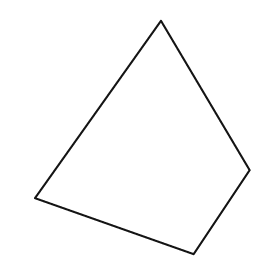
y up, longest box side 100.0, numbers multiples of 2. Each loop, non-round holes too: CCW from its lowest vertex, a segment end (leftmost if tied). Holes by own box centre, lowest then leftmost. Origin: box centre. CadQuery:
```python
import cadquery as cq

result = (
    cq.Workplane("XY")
    .moveTo(22.0, -50.0)
    .lineTo(46.0, -14.0)
    .lineTo(8.0, 50.0)
    .lineTo(-46.0, -26.0)
    .close()
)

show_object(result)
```